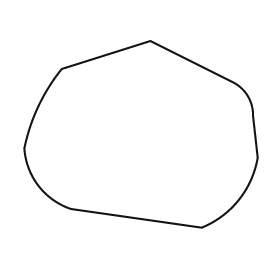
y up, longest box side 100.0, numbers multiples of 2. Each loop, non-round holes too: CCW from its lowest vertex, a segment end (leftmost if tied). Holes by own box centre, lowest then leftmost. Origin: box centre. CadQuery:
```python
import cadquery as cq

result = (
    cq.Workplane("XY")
    .moveTo(26.0, -40.0)
    .threePointArc((42.0, -28.0), (50.0, -10.0))
    .lineTo(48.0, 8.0)
    .threePointArc((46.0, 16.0), (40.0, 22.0))
    .lineTo(4.0, 40.0)
    .lineTo(-34.0, 28.0)
    .threePointArc((-44.0, 12.0), (-50.0, -6.0))
    .threePointArc((-44.0, -22.0), (-30.0, -32.0))
    .close()
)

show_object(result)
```